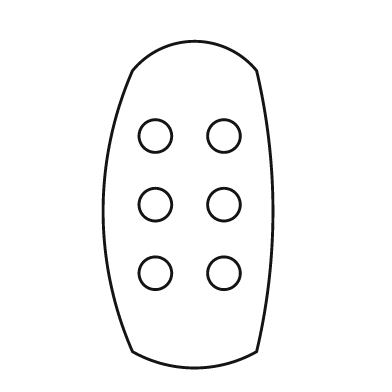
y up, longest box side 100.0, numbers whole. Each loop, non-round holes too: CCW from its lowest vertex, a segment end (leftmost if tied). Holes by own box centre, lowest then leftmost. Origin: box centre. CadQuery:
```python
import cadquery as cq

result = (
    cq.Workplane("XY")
    .moveTo(-17.0, -45.0)
    .threePointArc((2.0, -50.0), (21.0, -45.0))
    .threePointArc((26.0, -2.0), (21.0, 41.0))
    .threePointArc((2.0, 50.0), (-17.0, 41.0))
    .threePointArc((-26.0, -2.0), (-17.0, -45.0))
    .close()
    .moveTo(-10.0, -21.0)
    .circle(5.0)
    .moveTo(11.0, -21.0)
    .circle(5.0)
    .moveTo(-10.0, 0.0)
    .circle(5.0)
    .moveTo(11.0, 0.0)
    .circle(5.0)
    .moveTo(-10.0, 21.0)
    .circle(5.0)
    .moveTo(11.0, 21.0)
    .circle(5.0)
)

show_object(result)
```